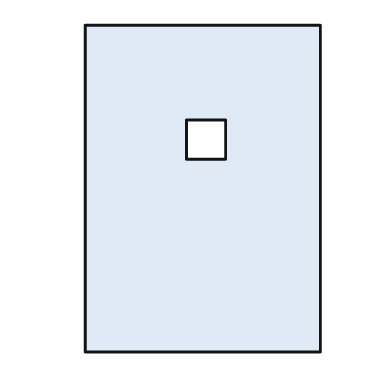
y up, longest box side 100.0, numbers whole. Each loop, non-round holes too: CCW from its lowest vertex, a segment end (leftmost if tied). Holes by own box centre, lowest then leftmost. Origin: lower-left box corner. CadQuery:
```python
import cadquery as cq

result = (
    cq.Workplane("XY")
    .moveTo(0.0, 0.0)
    .lineTo(72.0, 0.0)
    .lineTo(72.0, 100.0)
    .lineTo(0.0, 100.0)
    .close()
    .moveTo(31.0, 59.0)
    .lineTo(43.0, 59.0)
    .lineTo(43.0, 71.0)
    .lineTo(31.0, 71.0)
    .close()
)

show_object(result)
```